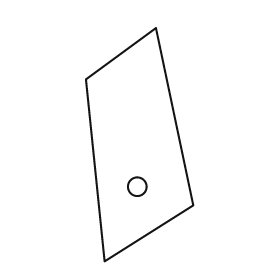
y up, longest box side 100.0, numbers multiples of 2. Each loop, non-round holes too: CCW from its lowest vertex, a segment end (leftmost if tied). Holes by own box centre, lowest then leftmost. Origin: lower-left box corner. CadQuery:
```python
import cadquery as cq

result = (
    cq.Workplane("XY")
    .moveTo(8.0, 0.0)
    .lineTo(46.0, 24.0)
    .lineTo(30.0, 100.0)
    .lineTo(0.0, 78.0)
    .close()
    .moveTo(22.0, 32.0)
    .circle(4.0)
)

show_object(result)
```